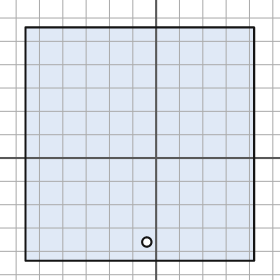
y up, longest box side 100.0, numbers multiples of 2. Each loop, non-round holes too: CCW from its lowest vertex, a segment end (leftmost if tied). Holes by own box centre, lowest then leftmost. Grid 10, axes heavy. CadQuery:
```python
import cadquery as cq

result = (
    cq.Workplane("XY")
    .moveTo(-56.0, -44.0)
    .lineTo(42.0, -44.0)
    .lineTo(42.0, 56.0)
    .lineTo(-56.0, 56.0)
    .close()
    .moveTo(-4.0, -36.0)
    .circle(2.0)
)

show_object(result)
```